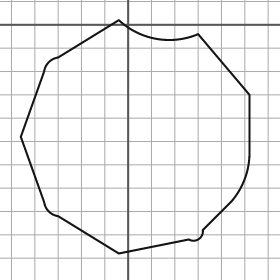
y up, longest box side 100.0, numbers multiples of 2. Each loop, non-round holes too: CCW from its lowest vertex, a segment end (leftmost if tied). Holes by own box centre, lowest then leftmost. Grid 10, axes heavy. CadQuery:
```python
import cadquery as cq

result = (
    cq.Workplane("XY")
    .moveTo(-4.0, -98.0)
    .lineTo(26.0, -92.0)
    .threePointArc((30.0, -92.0), (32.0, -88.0))
    .lineTo(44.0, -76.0)
    .threePointArc((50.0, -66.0), (52.0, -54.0))
    .lineTo(52.0, -30.0)
    .lineTo(30.0, -4.0)
    .threePointArc((12.0, -6.0), (-4.0, 2.0))
    .lineTo(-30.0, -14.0)
    .threePointArc((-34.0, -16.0), (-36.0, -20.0))
    .lineTo(-46.0, -48.0)
    .lineTo(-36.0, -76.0)
    .threePointArc((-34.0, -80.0), (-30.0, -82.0))
    .close()
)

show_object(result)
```